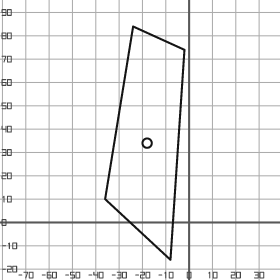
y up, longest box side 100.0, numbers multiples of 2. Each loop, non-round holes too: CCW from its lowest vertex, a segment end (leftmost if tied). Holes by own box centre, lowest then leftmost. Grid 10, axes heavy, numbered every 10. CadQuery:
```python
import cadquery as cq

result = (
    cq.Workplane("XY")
    .moveTo(-8.0, -16.0)
    .lineTo(-2.0, 74.0)
    .lineTo(-24.0, 84.0)
    .lineTo(-36.0, 10.0)
    .close()
    .moveTo(-18.0, 34.0)
    .circle(2.0)
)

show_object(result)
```